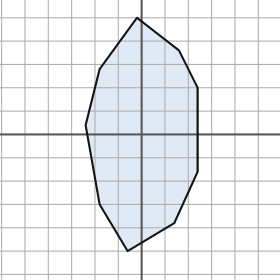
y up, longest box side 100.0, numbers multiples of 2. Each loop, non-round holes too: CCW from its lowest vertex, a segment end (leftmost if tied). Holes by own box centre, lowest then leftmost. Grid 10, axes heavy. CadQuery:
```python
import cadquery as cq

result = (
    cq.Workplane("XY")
    .moveTo(-6.0, -50.0)
    .lineTo(14.0, -38.0)
    .lineTo(24.0, -16.0)
    .lineTo(24.0, 20.0)
    .lineTo(16.0, 36.0)
    .lineTo(-2.0, 50.0)
    .lineTo(-18.0, 28.0)
    .lineTo(-24.0, 4.0)
    .lineTo(-18.0, -30.0)
    .close()
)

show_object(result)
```